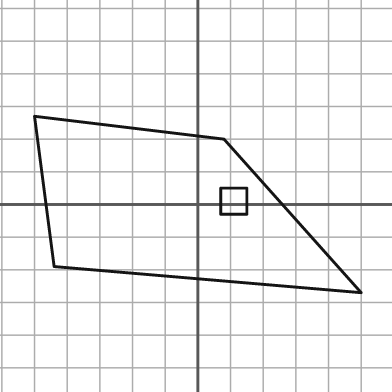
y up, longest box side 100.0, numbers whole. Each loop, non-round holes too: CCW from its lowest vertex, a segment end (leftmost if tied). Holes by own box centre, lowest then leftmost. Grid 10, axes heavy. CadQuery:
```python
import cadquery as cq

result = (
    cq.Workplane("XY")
    .moveTo(50.0, -27.0)
    .lineTo(8.0, 20.0)
    .lineTo(-50.0, 27.0)
    .lineTo(-44.0, -19.0)
    .close()
    .moveTo(7.0, -3.0)
    .lineTo(15.0, -3.0)
    .lineTo(15.0, 5.0)
    .lineTo(7.0, 5.0)
    .close()
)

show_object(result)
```